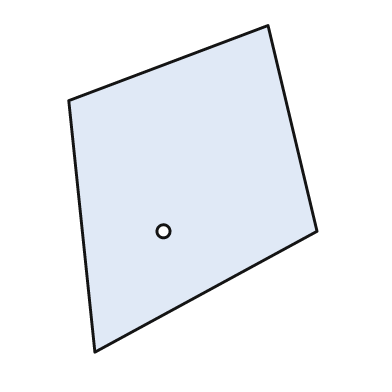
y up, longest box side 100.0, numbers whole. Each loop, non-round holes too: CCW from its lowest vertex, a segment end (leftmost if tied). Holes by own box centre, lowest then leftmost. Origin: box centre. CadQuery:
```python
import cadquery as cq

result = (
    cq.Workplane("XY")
    .moveTo(-30.0, -50.0)
    .lineTo(38.0, -13.0)
    .lineTo(23.0, 50.0)
    .lineTo(-38.0, 27.0)
    .close()
    .moveTo(-9.0, -13.0)
    .circle(2.0)
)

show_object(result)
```